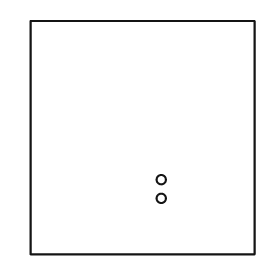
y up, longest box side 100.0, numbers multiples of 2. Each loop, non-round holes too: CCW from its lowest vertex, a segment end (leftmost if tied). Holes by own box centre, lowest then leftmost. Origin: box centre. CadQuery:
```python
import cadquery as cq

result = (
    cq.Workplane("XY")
    .moveTo(-48.0, -50.0)
    .lineTo(48.0, -50.0)
    .lineTo(48.0, 50.0)
    .lineTo(-48.0, 50.0)
    .close()
    .moveTo(8.0, -26.0)
    .circle(2.0)
    .moveTo(8.0, -18.0)
    .circle(2.0)
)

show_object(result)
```